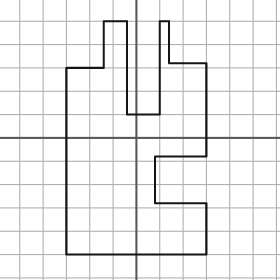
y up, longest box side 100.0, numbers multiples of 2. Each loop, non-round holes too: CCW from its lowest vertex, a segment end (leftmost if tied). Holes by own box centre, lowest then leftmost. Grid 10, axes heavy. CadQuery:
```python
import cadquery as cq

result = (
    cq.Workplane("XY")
    .moveTo(-30.0, -50.0)
    .lineTo(30.0, -50.0)
    .lineTo(30.0, -28.0)
    .lineTo(8.0, -28.0)
    .lineTo(8.0, -8.0)
    .lineTo(30.0, -8.0)
    .lineTo(30.0, 32.0)
    .lineTo(14.0, 32.0)
    .lineTo(14.0, 50.0)
    .lineTo(10.0, 50.0)
    .lineTo(10.0, 10.0)
    .lineTo(-4.0, 10.0)
    .lineTo(-4.0, 50.0)
    .lineTo(-14.0, 50.0)
    .lineTo(-14.0, 30.0)
    .lineTo(-30.0, 30.0)
    .close()
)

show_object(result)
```